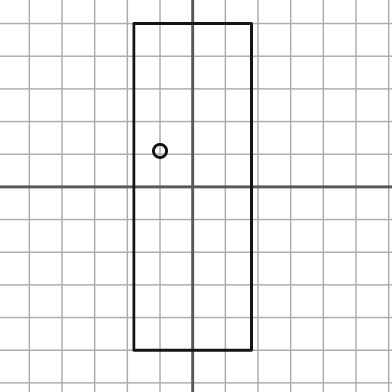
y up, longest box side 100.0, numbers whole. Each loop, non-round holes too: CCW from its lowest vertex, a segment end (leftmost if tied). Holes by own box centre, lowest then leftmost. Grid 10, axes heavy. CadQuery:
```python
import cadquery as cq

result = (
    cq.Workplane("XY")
    .moveTo(-18.0, -50.0)
    .lineTo(18.0, -50.0)
    .lineTo(18.0, 50.0)
    .lineTo(-18.0, 50.0)
    .close()
    .moveTo(-10.0, 11.0)
    .circle(2.0)
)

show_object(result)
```